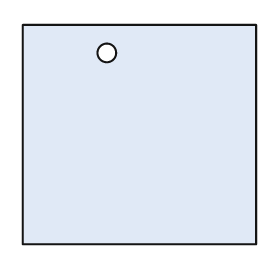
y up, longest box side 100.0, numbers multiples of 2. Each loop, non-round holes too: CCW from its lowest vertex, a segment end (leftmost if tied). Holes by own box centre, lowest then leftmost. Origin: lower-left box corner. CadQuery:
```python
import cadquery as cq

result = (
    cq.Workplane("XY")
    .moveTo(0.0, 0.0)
    .lineTo(100.0, 0.0)
    .lineTo(100.0, 94.0)
    .lineTo(0.0, 94.0)
    .close()
    .moveTo(36.0, 82.0)
    .circle(4.0)
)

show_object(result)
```